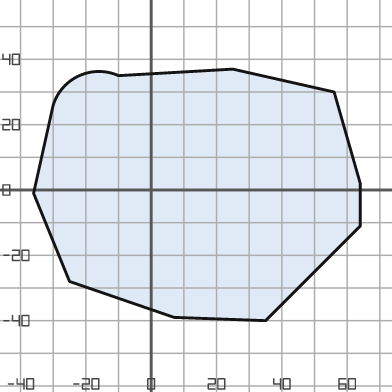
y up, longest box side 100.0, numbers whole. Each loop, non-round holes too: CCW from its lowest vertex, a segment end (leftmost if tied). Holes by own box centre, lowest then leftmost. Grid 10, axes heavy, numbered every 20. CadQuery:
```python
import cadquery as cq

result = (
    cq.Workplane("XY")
    .moveTo(35.0, -40.0)
    .lineTo(64.0, -11.0)
    .lineTo(64.0, 2.0)
    .lineTo(56.0, 30.0)
    .lineTo(25.0, 37.0)
    .lineTo(-10.0, 35.0)
    .threePointArc((-22.0, 35.0), (-30.0, 26.0))
    .lineTo(-36.0, -1.0)
    .lineTo(-25.0, -28.0)
    .lineTo(7.0, -39.0)
    .close()
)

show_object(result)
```